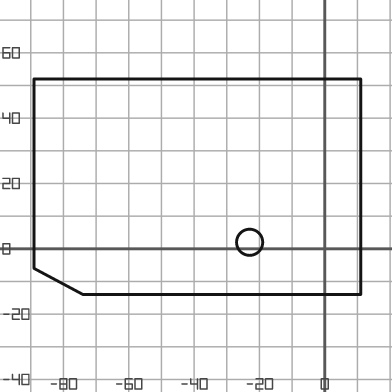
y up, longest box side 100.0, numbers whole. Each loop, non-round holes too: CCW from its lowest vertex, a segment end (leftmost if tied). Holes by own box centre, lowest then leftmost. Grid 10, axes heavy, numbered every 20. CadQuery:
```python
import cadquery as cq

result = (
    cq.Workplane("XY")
    .moveTo(-74.0, -14.0)
    .lineTo(11.0, -14.0)
    .lineTo(11.0, 52.0)
    .lineTo(-89.0, 52.0)
    .lineTo(-89.0, -6.0)
    .close()
    .moveTo(-23.0, 2.0)
    .circle(4.0)
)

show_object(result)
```